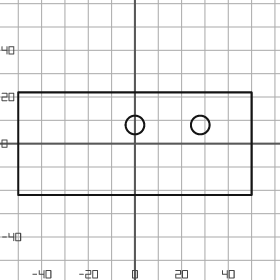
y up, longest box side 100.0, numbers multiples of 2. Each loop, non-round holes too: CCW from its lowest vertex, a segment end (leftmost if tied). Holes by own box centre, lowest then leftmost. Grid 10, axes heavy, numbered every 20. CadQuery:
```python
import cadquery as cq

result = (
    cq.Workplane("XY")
    .moveTo(-50.0, -22.0)
    .lineTo(50.0, -22.0)
    .lineTo(50.0, 22.0)
    .lineTo(-50.0, 22.0)
    .close()
    .moveTo(0.0, 8.0)
    .circle(4.0)
    .moveTo(28.0, 8.0)
    .circle(4.0)
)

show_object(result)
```